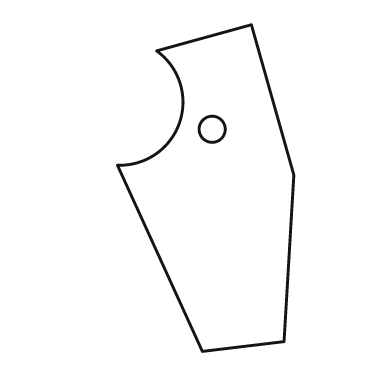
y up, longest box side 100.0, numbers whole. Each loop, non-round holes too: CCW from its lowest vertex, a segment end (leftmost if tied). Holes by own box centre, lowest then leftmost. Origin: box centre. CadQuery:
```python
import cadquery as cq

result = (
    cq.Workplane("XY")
    .moveTo(-1.0, -50.0)
    .lineTo(24.0, -47.0)
    .lineTo(27.0, 4.0)
    .lineTo(14.0, 50.0)
    .lineTo(-15.0, 42.0)
    .threePointArc((-8.0, 20.0), (-27.0, 7.0))
    .close()
    .moveTo(2.0, 18.0)
    .circle(4.0)
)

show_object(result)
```